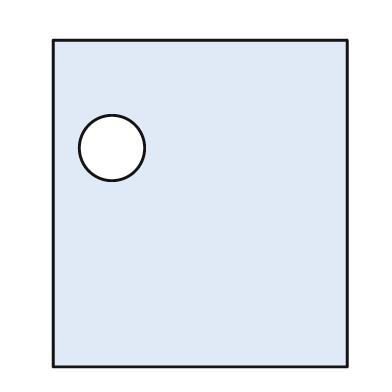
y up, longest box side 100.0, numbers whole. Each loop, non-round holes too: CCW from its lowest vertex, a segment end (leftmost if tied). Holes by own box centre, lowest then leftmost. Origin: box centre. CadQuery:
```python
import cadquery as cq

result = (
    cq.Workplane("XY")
    .moveTo(-45.0, -50.0)
    .lineTo(45.0, -50.0)
    .lineTo(45.0, 50.0)
    .lineTo(-45.0, 50.0)
    .close()
    .moveTo(-27.0, 17.0)
    .circle(10.0)
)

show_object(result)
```